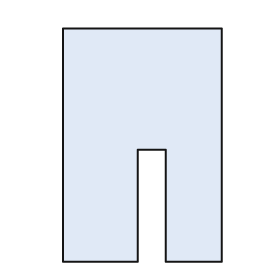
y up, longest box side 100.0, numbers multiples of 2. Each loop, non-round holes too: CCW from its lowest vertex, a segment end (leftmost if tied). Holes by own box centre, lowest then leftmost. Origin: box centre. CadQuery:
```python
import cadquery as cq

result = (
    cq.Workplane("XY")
    .moveTo(-34.0, -50.0)
    .lineTo(-2.0, -50.0)
    .lineTo(-2.0, -2.0)
    .lineTo(10.0, -2.0)
    .lineTo(10.0, -50.0)
    .lineTo(34.0, -50.0)
    .lineTo(34.0, 50.0)
    .lineTo(-34.0, 50.0)
    .close()
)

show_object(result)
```